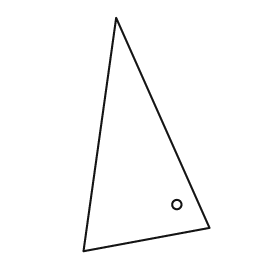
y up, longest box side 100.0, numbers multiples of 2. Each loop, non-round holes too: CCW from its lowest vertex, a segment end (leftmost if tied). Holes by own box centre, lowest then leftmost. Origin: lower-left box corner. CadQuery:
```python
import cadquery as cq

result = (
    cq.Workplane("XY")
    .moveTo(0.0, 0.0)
    .lineTo(54.0, 10.0)
    .lineTo(14.0, 100.0)
    .close()
    .moveTo(40.0, 20.0)
    .circle(2.0)
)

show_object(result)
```